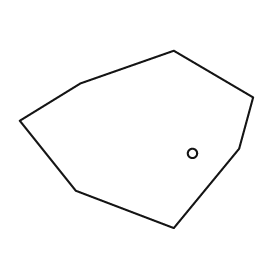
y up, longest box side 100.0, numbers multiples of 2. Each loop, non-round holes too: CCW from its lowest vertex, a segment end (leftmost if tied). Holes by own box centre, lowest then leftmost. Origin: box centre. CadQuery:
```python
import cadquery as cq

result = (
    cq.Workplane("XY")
    .moveTo(16.0, -38.0)
    .lineTo(44.0, -4.0)
    .lineTo(50.0, 18.0)
    .lineTo(16.0, 38.0)
    .lineTo(-24.0, 24.0)
    .lineTo(-50.0, 8.0)
    .lineTo(-26.0, -22.0)
    .close()
    .moveTo(24.0, -6.0)
    .circle(2.0)
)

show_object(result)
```